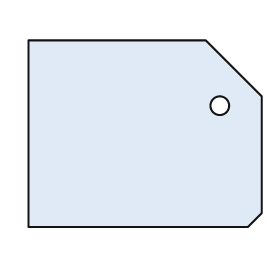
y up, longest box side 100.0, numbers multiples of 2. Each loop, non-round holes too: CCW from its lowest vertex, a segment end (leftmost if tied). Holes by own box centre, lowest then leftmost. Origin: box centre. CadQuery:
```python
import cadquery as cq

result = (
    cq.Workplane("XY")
    .moveTo(-50.0, -40.0)
    .lineTo(44.0, -40.0)
    .lineTo(50.0, -34.0)
    .lineTo(50.0, 16.0)
    .lineTo(26.0, 40.0)
    .lineTo(-50.0, 40.0)
    .close()
    .moveTo(32.0, 12.0)
    .circle(4.0)
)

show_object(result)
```